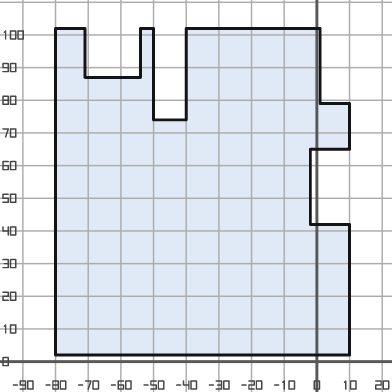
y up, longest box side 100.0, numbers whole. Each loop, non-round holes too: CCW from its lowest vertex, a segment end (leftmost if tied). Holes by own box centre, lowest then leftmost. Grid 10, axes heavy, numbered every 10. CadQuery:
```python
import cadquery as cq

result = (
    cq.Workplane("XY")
    .moveTo(-80.0, 2.0)
    .lineTo(10.0, 2.0)
    .lineTo(10.0, 42.0)
    .lineTo(-2.0, 42.0)
    .lineTo(-2.0, 65.0)
    .lineTo(10.0, 65.0)
    .lineTo(10.0, 79.0)
    .lineTo(1.0, 79.0)
    .lineTo(1.0, 102.0)
    .lineTo(-40.0, 102.0)
    .lineTo(-40.0, 74.0)
    .lineTo(-50.0, 74.0)
    .lineTo(-50.0, 102.0)
    .lineTo(-54.0, 102.0)
    .lineTo(-54.0, 87.0)
    .lineTo(-71.0, 87.0)
    .lineTo(-71.0, 102.0)
    .lineTo(-80.0, 102.0)
    .close()
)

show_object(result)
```